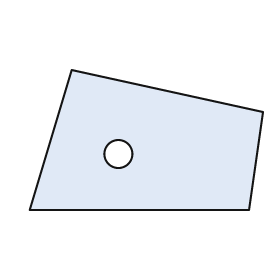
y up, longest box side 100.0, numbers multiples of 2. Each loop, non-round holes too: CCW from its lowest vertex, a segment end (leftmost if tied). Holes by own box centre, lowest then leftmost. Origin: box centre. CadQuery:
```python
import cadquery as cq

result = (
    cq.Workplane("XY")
    .moveTo(-50.0, -30.0)
    .lineTo(44.0, -30.0)
    .lineTo(50.0, 12.0)
    .lineTo(-32.0, 30.0)
    .close()
    .moveTo(-12.0, -6.0)
    .circle(6.0)
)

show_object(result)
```